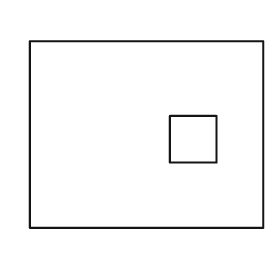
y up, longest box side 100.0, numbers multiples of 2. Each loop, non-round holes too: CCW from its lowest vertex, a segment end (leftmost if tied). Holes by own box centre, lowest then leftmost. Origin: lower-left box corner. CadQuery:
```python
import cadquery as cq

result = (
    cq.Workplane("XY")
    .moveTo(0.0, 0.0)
    .lineTo(100.0, 0.0)
    .lineTo(100.0, 80.0)
    .lineTo(0.0, 80.0)
    .close()
    .moveTo(60.0, 28.0)
    .lineTo(80.0, 28.0)
    .lineTo(80.0, 48.0)
    .lineTo(60.0, 48.0)
    .close()
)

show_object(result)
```